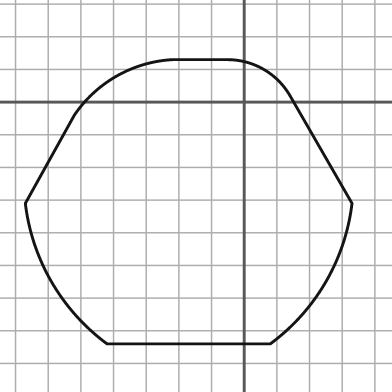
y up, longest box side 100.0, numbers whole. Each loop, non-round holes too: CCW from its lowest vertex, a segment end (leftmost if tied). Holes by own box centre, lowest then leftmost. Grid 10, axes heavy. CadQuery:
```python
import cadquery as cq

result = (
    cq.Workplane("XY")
    .moveTo(-42.0, -74.0)
    .lineTo(8.0, -74.0)
    .threePointArc((25.0, -55.0), (33.0, -31.0))
    .lineTo(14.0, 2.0)
    .threePointArc((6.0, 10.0), (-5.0, 13.0))
    .lineTo(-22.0, 13.0)
    .threePointArc((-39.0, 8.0), (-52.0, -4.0))
    .lineTo(-67.0, -31.0)
    .threePointArc((-59.0, -55.0), (-42.0, -74.0))
    .close()
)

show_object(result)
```